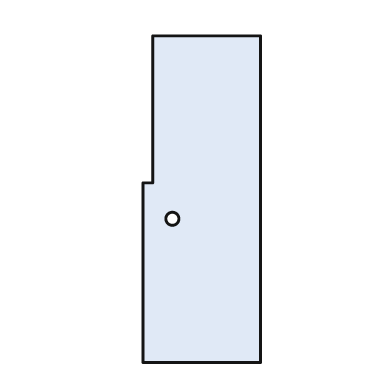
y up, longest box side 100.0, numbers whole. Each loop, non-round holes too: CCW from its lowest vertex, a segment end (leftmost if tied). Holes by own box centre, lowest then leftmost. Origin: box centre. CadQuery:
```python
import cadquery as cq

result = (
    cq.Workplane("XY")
    .moveTo(-18.0, -50.0)
    .lineTo(18.0, -50.0)
    .lineTo(18.0, 50.0)
    .lineTo(-15.0, 50.0)
    .lineTo(-15.0, 5.0)
    .lineTo(-18.0, 5.0)
    .close()
    .moveTo(-9.0, -6.0)
    .circle(2.0)
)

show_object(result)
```